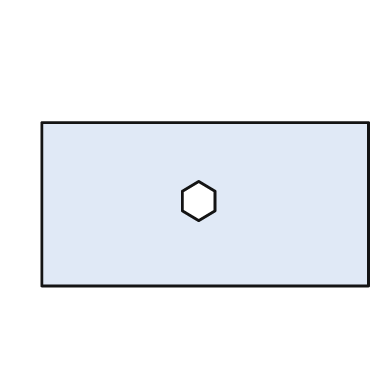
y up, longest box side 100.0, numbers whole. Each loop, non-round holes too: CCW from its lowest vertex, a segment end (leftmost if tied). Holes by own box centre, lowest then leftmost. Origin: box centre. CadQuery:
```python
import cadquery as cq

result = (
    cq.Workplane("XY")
    .moveTo(-50.0, -25.0)
    .lineTo(50.0, -25.0)
    .lineTo(50.0, 25.0)
    .lineTo(-50.0, 25.0)
    .close()
    .moveTo(-2.0, -5.0)
    .lineTo(3.0, -2.0)
    .lineTo(3.0, 4.0)
    .lineTo(-2.0, 7.0)
    .lineTo(-7.0, 4.0)
    .lineTo(-7.0, -2.0)
    .close()
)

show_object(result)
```